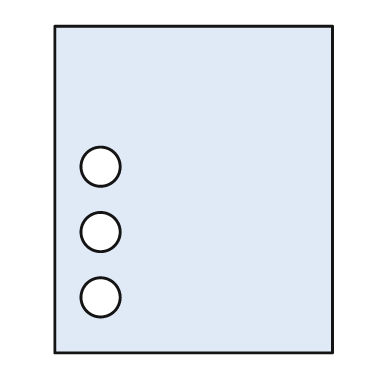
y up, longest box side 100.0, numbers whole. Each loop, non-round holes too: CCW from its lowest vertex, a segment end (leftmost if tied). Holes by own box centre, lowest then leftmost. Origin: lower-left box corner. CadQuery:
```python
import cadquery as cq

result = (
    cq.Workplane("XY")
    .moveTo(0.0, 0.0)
    .lineTo(85.0, 0.0)
    .lineTo(85.0, 100.0)
    .lineTo(0.0, 100.0)
    .close()
    .moveTo(14.0, 17.0)
    .circle(6.0)
    .moveTo(14.0, 37.0)
    .circle(6.0)
    .moveTo(14.0, 57.0)
    .circle(6.0)
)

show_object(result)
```